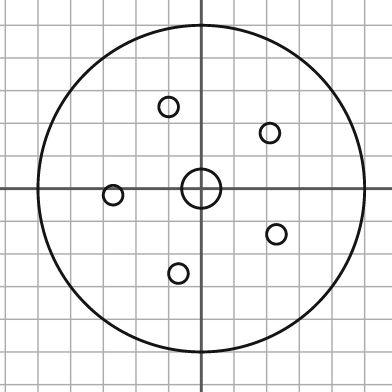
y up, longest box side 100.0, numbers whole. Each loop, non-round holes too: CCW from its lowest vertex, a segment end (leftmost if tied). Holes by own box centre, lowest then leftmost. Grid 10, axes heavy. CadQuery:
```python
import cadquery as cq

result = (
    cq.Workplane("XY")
    .moveTo(0.0, 0.0)
    .circle(50.0)
    .moveTo(-7.0, -26.0)
    .circle(3.0)
    .moveTo(23.0, -14.0)
    .circle(3.0)
    .moveTo(-27.0, -2.0)
    .circle(3.0)
    .moveTo(0.0, 0.0)
    .circle(6.0)
    .moveTo(21.0, 17.0)
    .circle(3.0)
    .moveTo(-10.0, 25.0)
    .circle(3.0)
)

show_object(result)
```